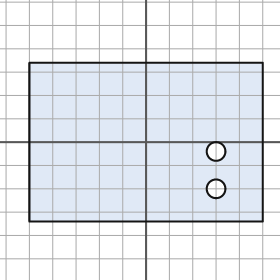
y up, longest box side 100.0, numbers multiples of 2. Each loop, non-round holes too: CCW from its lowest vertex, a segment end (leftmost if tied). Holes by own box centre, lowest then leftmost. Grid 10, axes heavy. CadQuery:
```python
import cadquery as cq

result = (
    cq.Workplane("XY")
    .moveTo(-50.0, -34.0)
    .lineTo(50.0, -34.0)
    .lineTo(50.0, 34.0)
    .lineTo(-50.0, 34.0)
    .close()
    .moveTo(30.0, -20.0)
    .circle(4.0)
    .moveTo(30.0, -4.0)
    .circle(4.0)
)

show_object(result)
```